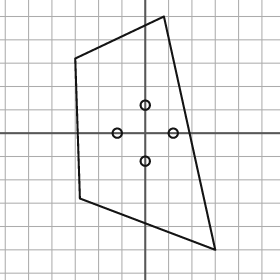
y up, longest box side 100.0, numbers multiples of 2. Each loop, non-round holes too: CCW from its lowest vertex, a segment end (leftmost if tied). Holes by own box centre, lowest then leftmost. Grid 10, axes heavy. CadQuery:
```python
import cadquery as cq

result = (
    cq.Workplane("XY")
    .moveTo(30.0, -50.0)
    .lineTo(8.0, 50.0)
    .lineTo(-30.0, 32.0)
    .lineTo(-28.0, -28.0)
    .close()
    .moveTo(0.0, -12.0)
    .circle(2.0)
    .moveTo(-12.0, 0.0)
    .circle(2.0)
    .moveTo(12.0, 0.0)
    .circle(2.0)
    .moveTo(0.0, 12.0)
    .circle(2.0)
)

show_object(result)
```